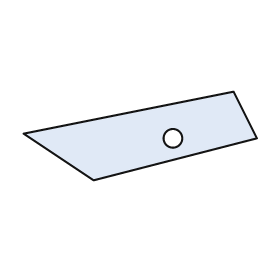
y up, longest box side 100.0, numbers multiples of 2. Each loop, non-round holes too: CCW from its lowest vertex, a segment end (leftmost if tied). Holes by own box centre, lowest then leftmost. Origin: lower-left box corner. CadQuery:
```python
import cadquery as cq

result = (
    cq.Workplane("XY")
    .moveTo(30.0, 0.0)
    .lineTo(100.0, 18.0)
    .lineTo(90.0, 38.0)
    .lineTo(0.0, 20.0)
    .close()
    .moveTo(64.0, 18.0)
    .circle(4.0)
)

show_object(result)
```